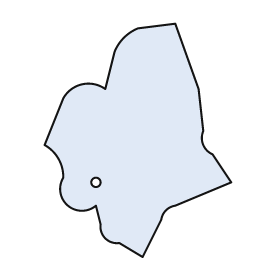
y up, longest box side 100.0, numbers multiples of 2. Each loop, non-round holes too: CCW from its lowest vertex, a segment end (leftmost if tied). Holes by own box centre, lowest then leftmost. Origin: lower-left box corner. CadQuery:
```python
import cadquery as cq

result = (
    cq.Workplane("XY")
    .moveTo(42.0, 0.0)
    .lineTo(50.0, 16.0)
    .threePointArc((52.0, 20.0), (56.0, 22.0))
    .lineTo(80.0, 32.0)
    .lineTo(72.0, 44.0)
    .threePointArc((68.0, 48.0), (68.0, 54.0))
    .lineTo(66.0, 72.0)
    .lineTo(56.0, 100.0)
    .lineTo(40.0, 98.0)
    .threePointArc((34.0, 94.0), (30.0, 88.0))
    .lineTo(26.0, 72.0)
    .threePointArc((16.0, 74.0), (8.0, 68.0))
    .lineTo(0.0, 48.0)
    .threePointArc((6.0, 42.0), (8.0, 34.0))
    .threePointArc((10.0, 22.0), (22.0, 22.0))
    .lineTo(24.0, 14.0)
    .threePointArc((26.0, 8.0), (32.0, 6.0))
    .close()
    .moveTo(22.0, 32.0)
    .circle(2.0)
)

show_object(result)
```